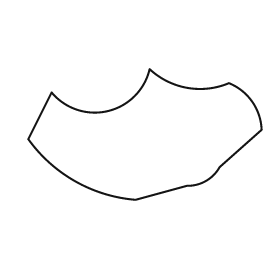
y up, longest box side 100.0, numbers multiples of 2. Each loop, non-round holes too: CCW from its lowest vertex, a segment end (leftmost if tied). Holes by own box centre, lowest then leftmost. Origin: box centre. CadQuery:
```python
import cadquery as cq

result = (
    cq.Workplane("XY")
    .moveTo(-4.0, -28.0)
    .lineTo(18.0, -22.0)
    .threePointArc((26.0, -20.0), (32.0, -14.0))
    .lineTo(50.0, 2.0)
    .threePointArc((46.0, 14.0), (36.0, 22.0))
    .threePointArc((18.0, 20.0), (2.0, 28.0))
    .threePointArc((-16.0, 10.0), (-40.0, 18.0))
    .lineTo(-50.0, -2.0)
    .threePointArc((-30.0, -20.0), (-4.0, -28.0))
    .close()
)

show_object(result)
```